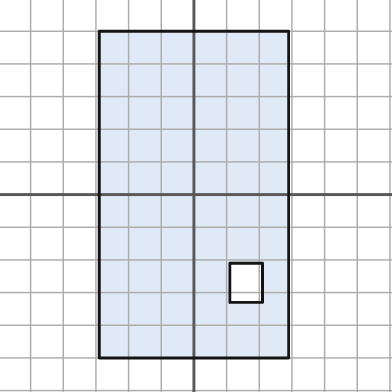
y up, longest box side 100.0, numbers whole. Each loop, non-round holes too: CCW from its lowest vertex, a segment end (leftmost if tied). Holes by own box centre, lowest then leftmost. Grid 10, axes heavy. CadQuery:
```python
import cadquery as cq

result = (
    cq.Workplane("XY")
    .moveTo(-29.0, -50.0)
    .lineTo(29.0, -50.0)
    .lineTo(29.0, 50.0)
    .lineTo(-29.0, 50.0)
    .close()
    .moveTo(11.0, -33.0)
    .lineTo(21.0, -33.0)
    .lineTo(21.0, -21.0)
    .lineTo(11.0, -21.0)
    .close()
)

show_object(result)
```